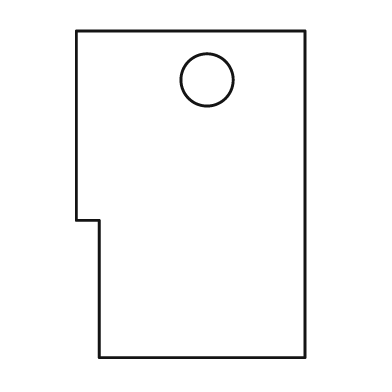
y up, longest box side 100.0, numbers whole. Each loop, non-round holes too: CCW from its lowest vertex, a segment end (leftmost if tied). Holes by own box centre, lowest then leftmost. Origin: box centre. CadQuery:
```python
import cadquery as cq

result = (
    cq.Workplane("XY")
    .moveTo(-28.0, -50.0)
    .lineTo(35.0, -50.0)
    .lineTo(35.0, 50.0)
    .lineTo(-35.0, 50.0)
    .lineTo(-35.0, -8.0)
    .lineTo(-28.0, -8.0)
    .close()
    .moveTo(5.0, 35.0)
    .circle(8.0)
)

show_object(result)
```